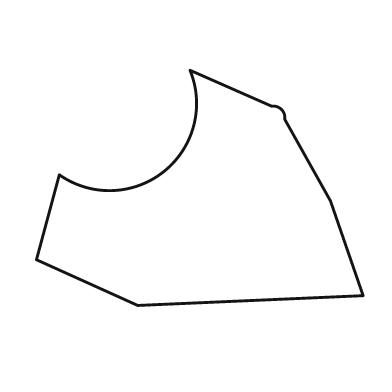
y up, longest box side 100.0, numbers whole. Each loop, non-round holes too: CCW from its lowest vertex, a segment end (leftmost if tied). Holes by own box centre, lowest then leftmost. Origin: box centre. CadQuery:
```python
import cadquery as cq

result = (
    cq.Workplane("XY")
    .moveTo(-19.0, -36.0)
    .lineTo(50.0, -33.0)
    .lineTo(40.0, -4.0)
    .lineTo(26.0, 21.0)
    .threePointArc((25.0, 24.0), (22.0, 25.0))
    .lineTo(-3.0, 36.0)
    .threePointArc((-11.0, 5.0), (-43.0, 4.0))
    .lineTo(-50.0, -22.0)
    .close()
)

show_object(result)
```